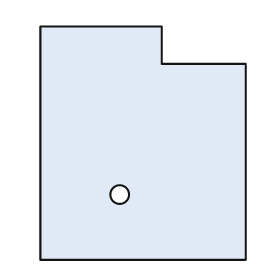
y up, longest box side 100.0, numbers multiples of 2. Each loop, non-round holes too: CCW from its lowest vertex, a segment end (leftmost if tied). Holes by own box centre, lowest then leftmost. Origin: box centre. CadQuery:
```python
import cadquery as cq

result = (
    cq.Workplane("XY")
    .moveTo(-44.0, -50.0)
    .lineTo(44.0, -50.0)
    .lineTo(44.0, 34.0)
    .lineTo(8.0, 34.0)
    .lineTo(8.0, 50.0)
    .lineTo(-44.0, 50.0)
    .close()
    .moveTo(-10.0, -22.0)
    .circle(4.0)
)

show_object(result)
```